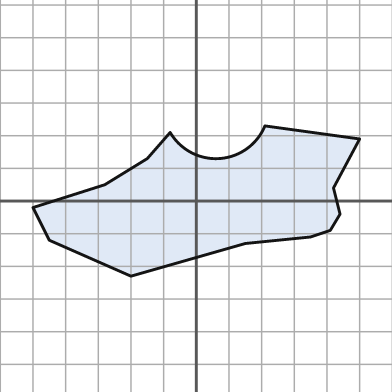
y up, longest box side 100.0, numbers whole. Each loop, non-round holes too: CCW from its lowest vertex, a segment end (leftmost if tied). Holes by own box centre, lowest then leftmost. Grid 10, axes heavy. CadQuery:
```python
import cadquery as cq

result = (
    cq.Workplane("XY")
    .moveTo(-20.0, -23.0)
    .lineTo(15.0, -13.0)
    .lineTo(35.0, -11.0)
    .lineTo(41.0, -9.0)
    .lineTo(44.0, -4.0)
    .lineTo(42.0, 4.0)
    .lineTo(50.0, 19.0)
    .lineTo(21.0, 23.0)
    .threePointArc((7.0, 13.0), (-8.0, 21.0))
    .lineTo(-15.0, 13.0)
    .lineTo(-28.0, 5.0)
    .lineTo(-50.0, -2.0)
    .lineTo(-45.0, -12.0)
    .close()
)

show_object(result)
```